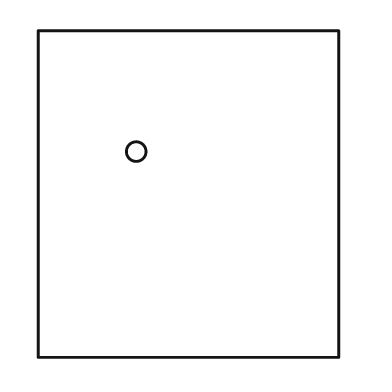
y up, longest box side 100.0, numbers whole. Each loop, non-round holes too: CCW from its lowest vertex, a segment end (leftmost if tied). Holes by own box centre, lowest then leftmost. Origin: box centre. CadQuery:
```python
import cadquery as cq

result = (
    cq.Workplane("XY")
    .moveTo(-46.0, -50.0)
    .lineTo(46.0, -50.0)
    .lineTo(46.0, 50.0)
    .lineTo(-46.0, 50.0)
    .close()
    .moveTo(-16.0, 13.0)
    .circle(3.0)
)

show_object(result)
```